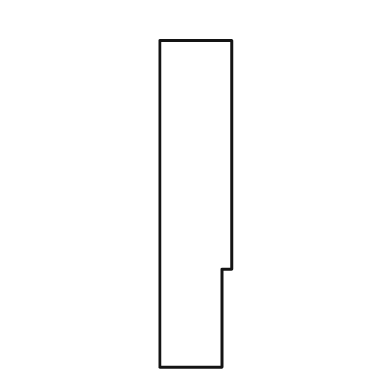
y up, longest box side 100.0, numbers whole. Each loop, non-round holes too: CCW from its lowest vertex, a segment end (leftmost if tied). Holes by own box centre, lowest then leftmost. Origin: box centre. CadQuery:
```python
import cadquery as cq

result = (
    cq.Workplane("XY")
    .moveTo(-11.0, -50.0)
    .lineTo(8.0, -50.0)
    .lineTo(8.0, -20.0)
    .lineTo(11.0, -20.0)
    .lineTo(11.0, 50.0)
    .lineTo(-11.0, 50.0)
    .close()
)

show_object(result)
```